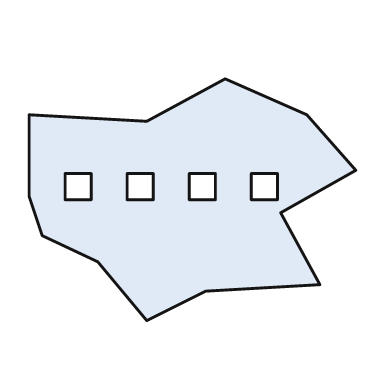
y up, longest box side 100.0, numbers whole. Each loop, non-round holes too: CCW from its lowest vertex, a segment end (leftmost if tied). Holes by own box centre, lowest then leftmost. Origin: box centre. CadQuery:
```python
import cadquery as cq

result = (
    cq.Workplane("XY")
    .moveTo(-14.0, -37.0)
    .lineTo(4.0, -28.0)
    .lineTo(39.0, -26.0)
    .lineTo(27.0, -4.0)
    .lineTo(50.0, 9.0)
    .lineTo(35.0, 26.0)
    .lineTo(10.0, 37.0)
    .lineTo(-14.0, 24.0)
    .lineTo(-50.0, 26.0)
    .lineTo(-50.0, 1.0)
    .lineTo(-46.0, -11.0)
    .lineTo(-29.0, -19.0)
    .close()
    .moveTo(-39.0, 0.0)
    .lineTo(-31.0, 0.0)
    .lineTo(-31.0, 8.0)
    .lineTo(-39.0, 8.0)
    .close()
    .moveTo(-20.0, 0.0)
    .lineTo(-12.0, 0.0)
    .lineTo(-12.0, 8.0)
    .lineTo(-20.0, 8.0)
    .close()
    .moveTo(-1.0, 0.0)
    .lineTo(7.0, 0.0)
    .lineTo(7.0, 8.0)
    .lineTo(-1.0, 8.0)
    .close()
    .moveTo(18.0, 0.0)
    .lineTo(26.0, 0.0)
    .lineTo(26.0, 8.0)
    .lineTo(18.0, 8.0)
    .close()
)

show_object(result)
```